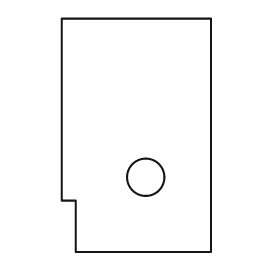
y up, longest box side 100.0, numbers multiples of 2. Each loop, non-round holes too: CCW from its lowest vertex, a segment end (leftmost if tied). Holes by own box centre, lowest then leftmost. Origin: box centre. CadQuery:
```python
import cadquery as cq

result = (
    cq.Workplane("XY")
    .moveTo(-26.0, -50.0)
    .lineTo(32.0, -50.0)
    .lineTo(32.0, 50.0)
    .lineTo(-32.0, 50.0)
    .lineTo(-32.0, -28.0)
    .lineTo(-26.0, -28.0)
    .close()
    .moveTo(4.0, -18.0)
    .circle(8.0)
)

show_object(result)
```